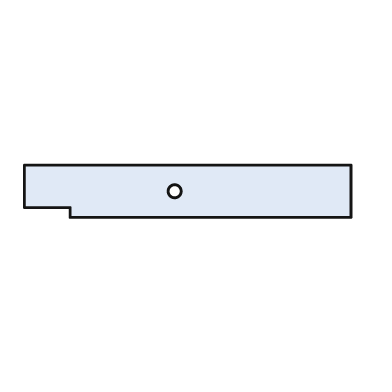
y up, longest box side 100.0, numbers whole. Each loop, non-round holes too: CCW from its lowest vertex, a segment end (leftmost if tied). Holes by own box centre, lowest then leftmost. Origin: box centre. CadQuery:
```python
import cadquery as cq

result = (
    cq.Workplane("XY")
    .moveTo(-36.0, -8.0)
    .lineTo(50.0, -8.0)
    .lineTo(50.0, 8.0)
    .lineTo(-50.0, 8.0)
    .lineTo(-50.0, -5.0)
    .lineTo(-36.0, -5.0)
    .close()
    .moveTo(-4.0, 0.0)
    .circle(2.0)
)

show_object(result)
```